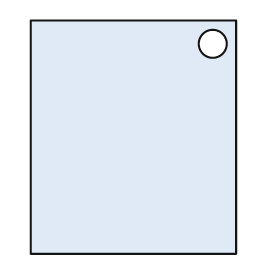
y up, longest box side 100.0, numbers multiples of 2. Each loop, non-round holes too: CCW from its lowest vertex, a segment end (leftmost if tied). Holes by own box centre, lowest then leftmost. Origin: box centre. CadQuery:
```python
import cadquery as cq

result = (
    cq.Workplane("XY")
    .moveTo(-44.0, -50.0)
    .lineTo(44.0, -50.0)
    .lineTo(44.0, 50.0)
    .lineTo(-44.0, 50.0)
    .close()
    .moveTo(34.0, 40.0)
    .circle(6.0)
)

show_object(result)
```